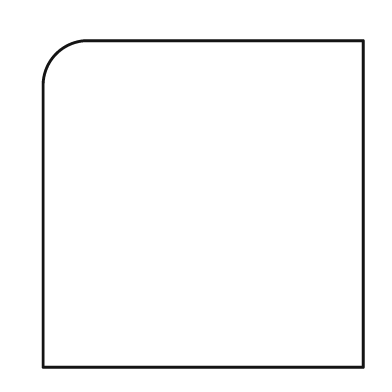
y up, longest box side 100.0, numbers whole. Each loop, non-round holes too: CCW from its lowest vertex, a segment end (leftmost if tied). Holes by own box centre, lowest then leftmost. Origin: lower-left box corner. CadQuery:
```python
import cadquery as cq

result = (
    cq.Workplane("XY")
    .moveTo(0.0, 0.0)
    .lineTo(98.0, 0.0)
    .lineTo(98.0, 100.0)
    .lineTo(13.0, 100.0)
    .threePointArc((4.0, 96.0), (0.0, 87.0))
    .close()
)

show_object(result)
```